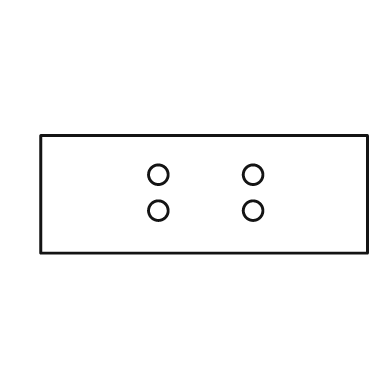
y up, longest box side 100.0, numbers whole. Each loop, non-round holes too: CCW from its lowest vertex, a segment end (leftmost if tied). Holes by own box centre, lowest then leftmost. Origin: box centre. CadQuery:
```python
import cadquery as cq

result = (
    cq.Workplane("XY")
    .moveTo(-50.0, -18.0)
    .lineTo(50.0, -18.0)
    .lineTo(50.0, 18.0)
    .lineTo(-50.0, 18.0)
    .close()
    .moveTo(-14.0, -5.0)
    .circle(3.0)
    .moveTo(15.0, -5.0)
    .circle(3.0)
    .moveTo(-14.0, 6.0)
    .circle(3.0)
    .moveTo(15.0, 6.0)
    .circle(3.0)
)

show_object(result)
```